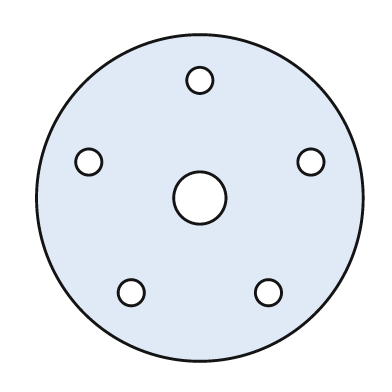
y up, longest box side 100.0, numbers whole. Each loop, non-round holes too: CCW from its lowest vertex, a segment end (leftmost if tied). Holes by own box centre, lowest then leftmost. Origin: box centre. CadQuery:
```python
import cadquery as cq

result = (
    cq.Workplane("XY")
    .moveTo(0.0, 0.0)
    .circle(50.0)
    .moveTo(-21.0, -29.0)
    .circle(4.0)
    .moveTo(21.0, -29.0)
    .circle(4.0)
    .moveTo(0.0, 0.0)
    .circle(8.0)
    .moveTo(-34.0, 11.0)
    .circle(4.0)
    .moveTo(34.0, 11.0)
    .circle(4.0)
    .moveTo(0.0, 36.0)
    .circle(4.0)
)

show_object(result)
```